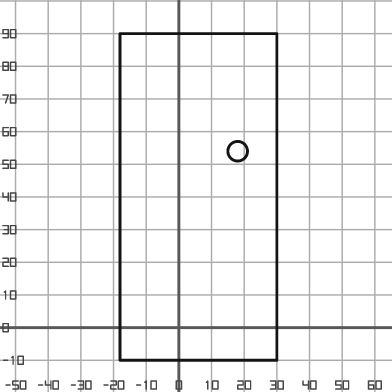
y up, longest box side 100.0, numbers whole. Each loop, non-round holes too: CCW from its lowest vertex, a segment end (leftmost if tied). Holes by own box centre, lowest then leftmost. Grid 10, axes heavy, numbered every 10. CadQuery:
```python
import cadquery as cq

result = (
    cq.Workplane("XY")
    .moveTo(-18.0, -10.0)
    .lineTo(30.0, -10.0)
    .lineTo(30.0, 90.0)
    .lineTo(-18.0, 90.0)
    .close()
    .moveTo(18.0, 54.0)
    .circle(3.0)
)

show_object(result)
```